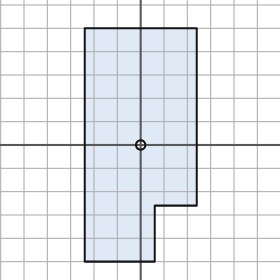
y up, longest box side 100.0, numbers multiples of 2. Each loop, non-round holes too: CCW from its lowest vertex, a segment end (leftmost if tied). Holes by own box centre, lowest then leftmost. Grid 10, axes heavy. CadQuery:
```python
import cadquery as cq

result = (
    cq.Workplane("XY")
    .moveTo(-24.0, -50.0)
    .lineTo(6.0, -50.0)
    .lineTo(6.0, -26.0)
    .lineTo(24.0, -26.0)
    .lineTo(24.0, 50.0)
    .lineTo(-24.0, 50.0)
    .close()
    .moveTo(0.0, 0.0)
    .circle(2.0)
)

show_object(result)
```